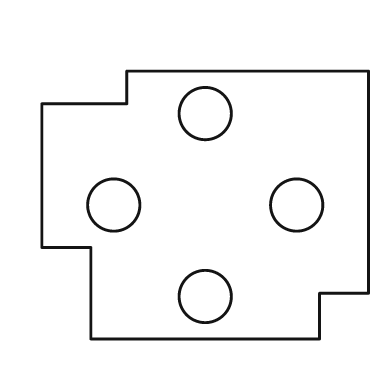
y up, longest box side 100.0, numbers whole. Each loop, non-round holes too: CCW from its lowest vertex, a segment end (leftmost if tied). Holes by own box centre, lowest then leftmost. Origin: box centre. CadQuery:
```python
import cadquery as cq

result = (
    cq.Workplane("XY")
    .moveTo(-35.0, -41.0)
    .lineTo(35.0, -41.0)
    .lineTo(35.0, -27.0)
    .lineTo(50.0, -27.0)
    .lineTo(50.0, 41.0)
    .lineTo(-24.0, 41.0)
    .lineTo(-24.0, 31.0)
    .lineTo(-50.0, 31.0)
    .lineTo(-50.0, -13.0)
    .lineTo(-35.0, -13.0)
    .close()
    .moveTo(0.0, -28.0)
    .circle(8.0)
    .moveTo(-28.0, 0.0)
    .circle(8.0)
    .moveTo(28.0, 0.0)
    .circle(8.0)
    .moveTo(0.0, 28.0)
    .circle(8.0)
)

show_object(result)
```